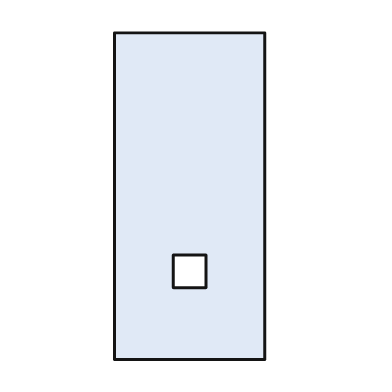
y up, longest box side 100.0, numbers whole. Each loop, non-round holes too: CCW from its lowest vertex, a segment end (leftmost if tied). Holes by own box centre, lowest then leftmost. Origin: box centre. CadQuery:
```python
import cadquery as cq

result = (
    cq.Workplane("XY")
    .moveTo(-23.0, -50.0)
    .lineTo(23.0, -50.0)
    .lineTo(23.0, 50.0)
    .lineTo(-23.0, 50.0)
    .close()
    .moveTo(-5.0, -28.0)
    .lineTo(5.0, -28.0)
    .lineTo(5.0, -18.0)
    .lineTo(-5.0, -18.0)
    .close()
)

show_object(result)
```